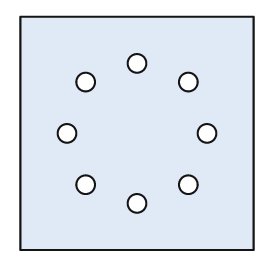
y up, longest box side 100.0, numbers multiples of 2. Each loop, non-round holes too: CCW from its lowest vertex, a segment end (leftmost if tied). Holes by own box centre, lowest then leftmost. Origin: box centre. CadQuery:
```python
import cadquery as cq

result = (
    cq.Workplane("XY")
    .moveTo(-50.0, -50.0)
    .lineTo(50.0, -50.0)
    .lineTo(50.0, 50.0)
    .lineTo(-50.0, 50.0)
    .close()
    .moveTo(0.0, -30.0)
    .circle(4.0)
    .moveTo(-22.0, -22.0)
    .circle(4.0)
    .moveTo(22.0, -22.0)
    .circle(4.0)
    .moveTo(-30.0, 0.0)
    .circle(4.0)
    .moveTo(30.0, 0.0)
    .circle(4.0)
    .moveTo(-22.0, 22.0)
    .circle(4.0)
    .moveTo(22.0, 22.0)
    .circle(4.0)
    .moveTo(0.0, 30.0)
    .circle(4.0)
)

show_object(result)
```